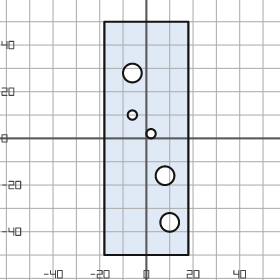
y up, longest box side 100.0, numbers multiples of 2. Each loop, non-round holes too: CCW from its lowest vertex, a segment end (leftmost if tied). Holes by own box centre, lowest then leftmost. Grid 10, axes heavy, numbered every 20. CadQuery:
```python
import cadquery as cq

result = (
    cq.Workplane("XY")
    .moveTo(-18.0, -50.0)
    .lineTo(18.0, -50.0)
    .lineTo(18.0, 50.0)
    .lineTo(-18.0, 50.0)
    .close()
    .moveTo(10.0, -36.0)
    .circle(4.0)
    .moveTo(8.0, -16.0)
    .circle(4.0)
    .moveTo(2.0, 2.0)
    .circle(2.0)
    .moveTo(-6.0, 10.0)
    .circle(2.0)
    .moveTo(-6.0, 28.0)
    .circle(4.0)
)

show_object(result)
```